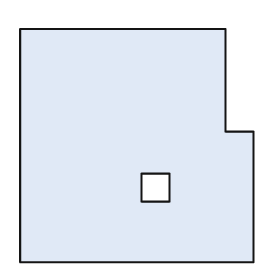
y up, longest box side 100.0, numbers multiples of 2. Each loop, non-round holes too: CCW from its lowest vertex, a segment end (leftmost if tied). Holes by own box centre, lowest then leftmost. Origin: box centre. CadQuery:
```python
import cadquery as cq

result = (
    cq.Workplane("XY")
    .moveTo(-50.0, -50.0)
    .lineTo(50.0, -50.0)
    .lineTo(50.0, 6.0)
    .lineTo(38.0, 6.0)
    .lineTo(38.0, 50.0)
    .lineTo(-50.0, 50.0)
    .close()
    .moveTo(2.0, -24.0)
    .lineTo(14.0, -24.0)
    .lineTo(14.0, -12.0)
    .lineTo(2.0, -12.0)
    .close()
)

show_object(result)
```